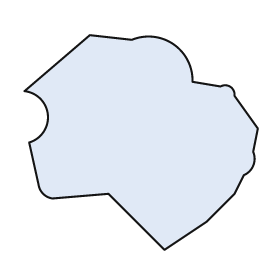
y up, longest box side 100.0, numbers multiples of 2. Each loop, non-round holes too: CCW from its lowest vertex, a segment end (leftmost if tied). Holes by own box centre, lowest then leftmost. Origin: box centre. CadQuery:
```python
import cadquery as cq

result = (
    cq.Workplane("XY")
    .moveTo(10.0, -46.0)
    .lineTo(28.0, -34.0)
    .lineTo(40.0, -22.0)
    .lineTo(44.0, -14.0)
    .threePointArc((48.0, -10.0), (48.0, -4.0))
    .lineTo(50.0, 6.0)
    .lineTo(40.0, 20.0)
    .threePointArc((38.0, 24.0), (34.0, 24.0))
    .lineTo(22.0, 26.0)
    .threePointArc((14.0, 42.0), (-4.0, 44.0))
    .lineTo(-22.0, 46.0)
    .lineTo(-50.0, 22.0)
    .threePointArc((-40.0, 12.0), (-48.0, 0.0))
    .lineTo(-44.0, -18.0)
    .threePointArc((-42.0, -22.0), (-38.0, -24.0))
    .lineTo(-14.0, -22.0)
    .close()
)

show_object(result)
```